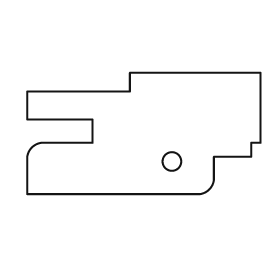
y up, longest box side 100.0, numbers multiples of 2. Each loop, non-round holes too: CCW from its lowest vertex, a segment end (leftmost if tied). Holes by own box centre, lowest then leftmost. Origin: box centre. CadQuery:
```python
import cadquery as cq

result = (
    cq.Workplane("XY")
    .moveTo(-50.0, -26.0)
    .lineTo(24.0, -26.0)
    .threePointArc((28.0, -24.0), (30.0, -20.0))
    .lineTo(30.0, -10.0)
    .lineTo(46.0, -10.0)
    .lineTo(46.0, -4.0)
    .lineTo(50.0, -4.0)
    .lineTo(50.0, 26.0)
    .lineTo(-6.0, 26.0)
    .lineTo(-6.0, 18.0)
    .lineTo(-50.0, 18.0)
    .lineTo(-50.0, 6.0)
    .lineTo(-22.0, 6.0)
    .lineTo(-22.0, -4.0)
    .lineTo(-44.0, -4.0)
    .threePointArc((-48.0, -6.0), (-50.0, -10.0))
    .close()
    .moveTo(12.0, -12.0)
    .circle(4.0)
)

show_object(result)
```